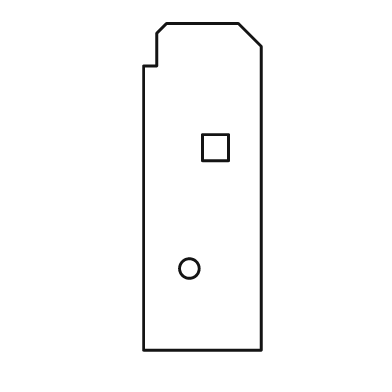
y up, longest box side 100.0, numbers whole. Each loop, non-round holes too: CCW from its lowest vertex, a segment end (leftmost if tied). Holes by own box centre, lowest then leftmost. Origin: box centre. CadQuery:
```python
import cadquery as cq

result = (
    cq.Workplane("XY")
    .moveTo(-18.0, -50.0)
    .lineTo(18.0, -50.0)
    .lineTo(18.0, 43.0)
    .lineTo(11.0, 50.0)
    .lineTo(-11.0, 50.0)
    .lineTo(-14.0, 47.0)
    .lineTo(-14.0, 37.0)
    .lineTo(-18.0, 37.0)
    .close()
    .moveTo(-4.0, -25.0)
    .circle(3.0)
    .moveTo(0.0, 8.0)
    .lineTo(8.0, 8.0)
    .lineTo(8.0, 16.0)
    .lineTo(0.0, 16.0)
    .close()
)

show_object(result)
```